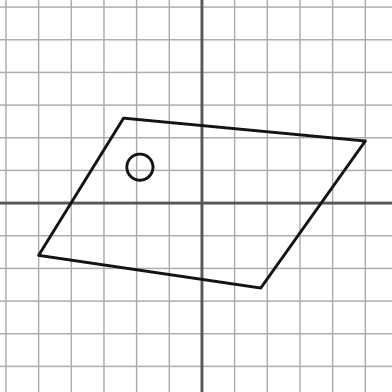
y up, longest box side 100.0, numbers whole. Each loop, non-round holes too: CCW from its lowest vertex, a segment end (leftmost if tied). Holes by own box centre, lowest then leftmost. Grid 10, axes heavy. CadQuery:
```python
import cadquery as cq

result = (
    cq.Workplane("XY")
    .moveTo(18.0, -26.0)
    .lineTo(50.0, 19.0)
    .lineTo(-24.0, 26.0)
    .lineTo(-50.0, -16.0)
    .close()
    .moveTo(-19.0, 11.0)
    .circle(4.0)
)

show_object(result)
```